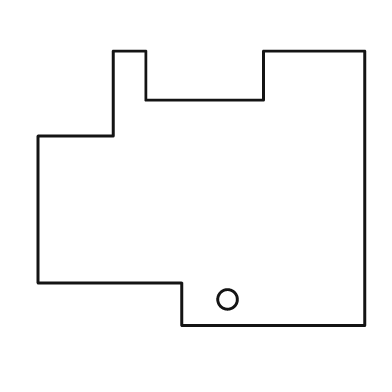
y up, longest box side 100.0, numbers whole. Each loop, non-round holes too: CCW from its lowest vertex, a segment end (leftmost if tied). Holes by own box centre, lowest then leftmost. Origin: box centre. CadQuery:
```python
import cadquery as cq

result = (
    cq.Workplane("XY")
    .moveTo(-6.0, -42.0)
    .lineTo(50.0, -42.0)
    .lineTo(50.0, 42.0)
    .lineTo(19.0, 42.0)
    .lineTo(19.0, 27.0)
    .lineTo(-17.0, 27.0)
    .lineTo(-17.0, 42.0)
    .lineTo(-27.0, 42.0)
    .lineTo(-27.0, 16.0)
    .lineTo(-50.0, 16.0)
    .lineTo(-50.0, -29.0)
    .lineTo(-6.0, -29.0)
    .close()
    .moveTo(8.0, -34.0)
    .circle(3.0)
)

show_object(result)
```